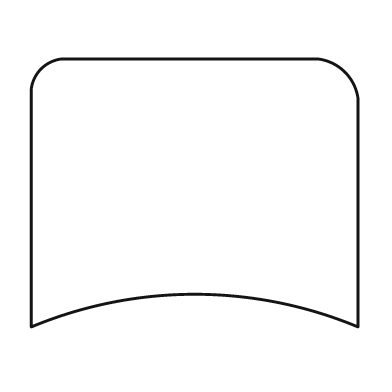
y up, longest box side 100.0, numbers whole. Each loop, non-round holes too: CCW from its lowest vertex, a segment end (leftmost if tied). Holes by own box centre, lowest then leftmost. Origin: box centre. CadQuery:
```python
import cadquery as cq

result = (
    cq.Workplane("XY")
    .moveTo(-50.0, -41.0)
    .threePointArc((0.0, -31.0), (50.0, -41.0))
    .lineTo(50.0, 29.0)
    .threePointArc((46.0, 37.0), (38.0, 41.0))
    .lineTo(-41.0, 41.0)
    .threePointArc((-47.0, 38.0), (-50.0, 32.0))
    .close()
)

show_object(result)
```